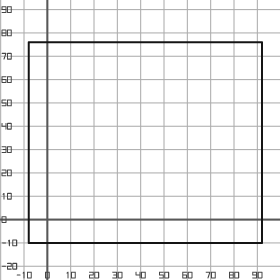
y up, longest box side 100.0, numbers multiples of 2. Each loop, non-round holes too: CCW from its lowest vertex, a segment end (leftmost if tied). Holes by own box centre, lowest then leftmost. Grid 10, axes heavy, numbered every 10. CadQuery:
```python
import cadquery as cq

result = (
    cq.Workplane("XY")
    .moveTo(-8.0, -10.0)
    .lineTo(92.0, -10.0)
    .lineTo(92.0, 76.0)
    .lineTo(-8.0, 76.0)
    .close()
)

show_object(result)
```